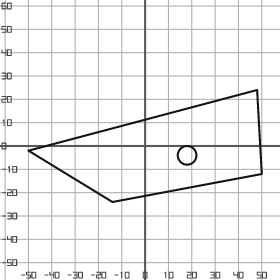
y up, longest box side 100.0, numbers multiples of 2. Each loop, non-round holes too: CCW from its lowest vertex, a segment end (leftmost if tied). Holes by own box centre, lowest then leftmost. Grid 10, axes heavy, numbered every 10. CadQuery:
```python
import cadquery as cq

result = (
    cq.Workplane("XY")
    .moveTo(-14.0, -24.0)
    .lineTo(50.0, -12.0)
    .lineTo(48.0, 24.0)
    .lineTo(-50.0, -2.0)
    .close()
    .moveTo(18.0, -4.0)
    .circle(4.0)
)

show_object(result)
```